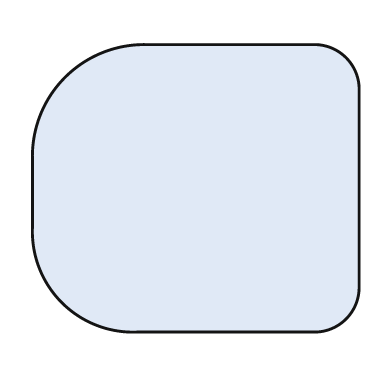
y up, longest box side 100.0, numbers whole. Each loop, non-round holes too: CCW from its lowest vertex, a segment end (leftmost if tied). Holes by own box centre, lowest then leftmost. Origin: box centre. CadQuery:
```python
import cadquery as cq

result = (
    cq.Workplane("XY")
    .moveTo(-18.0, -44.0)
    .lineTo(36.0, -44.0)
    .threePointArc((46.0, -40.0), (50.0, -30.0))
    .lineTo(50.0, 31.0)
    .threePointArc((46.0, 40.0), (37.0, 44.0))
    .lineTo(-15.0, 44.0)
    .threePointArc((-40.0, 34.0), (-50.0, 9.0))
    .lineTo(-50.0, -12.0)
    .threePointArc((-41.0, -35.0), (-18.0, -44.0))
    .close()
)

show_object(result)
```